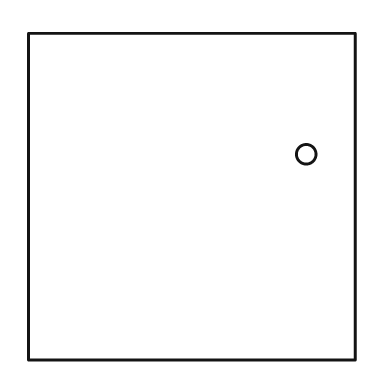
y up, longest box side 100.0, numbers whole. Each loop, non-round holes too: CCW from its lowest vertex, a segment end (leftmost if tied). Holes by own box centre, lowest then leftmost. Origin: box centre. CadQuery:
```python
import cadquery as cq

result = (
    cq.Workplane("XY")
    .moveTo(-50.0, -50.0)
    .lineTo(50.0, -50.0)
    .lineTo(50.0, 50.0)
    .lineTo(-50.0, 50.0)
    .close()
    .moveTo(35.0, 13.0)
    .circle(3.0)
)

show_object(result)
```